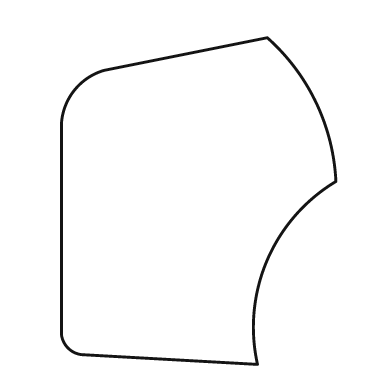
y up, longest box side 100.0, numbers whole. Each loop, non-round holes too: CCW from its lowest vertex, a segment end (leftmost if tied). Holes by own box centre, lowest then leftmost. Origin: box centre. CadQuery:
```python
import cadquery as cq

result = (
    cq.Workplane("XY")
    .moveTo(18.0, -50.0)
    .threePointArc((21.0, -18.0), (42.0, 6.0))
    .threePointArc((36.0, 30.0), (21.0, 50.0))
    .lineTo(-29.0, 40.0)
    .threePointArc((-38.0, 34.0), (-42.0, 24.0))
    .lineTo(-42.0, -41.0)
    .threePointArc((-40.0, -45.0), (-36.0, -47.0))
    .close()
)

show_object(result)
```